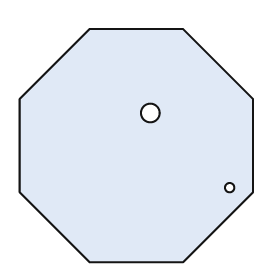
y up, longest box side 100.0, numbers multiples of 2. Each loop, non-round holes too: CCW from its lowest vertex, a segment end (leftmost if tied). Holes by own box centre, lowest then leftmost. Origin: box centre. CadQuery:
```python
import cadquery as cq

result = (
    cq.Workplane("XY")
    .moveTo(-20.0, -50.0)
    .lineTo(20.0, -50.0)
    .lineTo(50.0, -20.0)
    .lineTo(50.0, 20.0)
    .lineTo(20.0, 50.0)
    .lineTo(-20.0, 50.0)
    .lineTo(-50.0, 20.0)
    .lineTo(-50.0, -20.0)
    .close()
    .moveTo(40.0, -18.0)
    .circle(2.0)
    .moveTo(6.0, 14.0)
    .circle(4.0)
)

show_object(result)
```